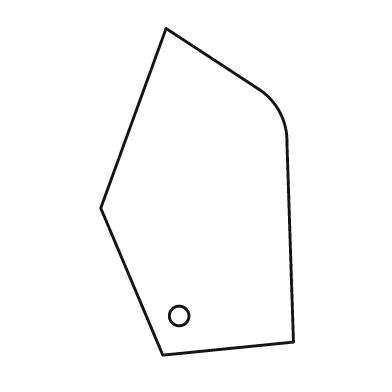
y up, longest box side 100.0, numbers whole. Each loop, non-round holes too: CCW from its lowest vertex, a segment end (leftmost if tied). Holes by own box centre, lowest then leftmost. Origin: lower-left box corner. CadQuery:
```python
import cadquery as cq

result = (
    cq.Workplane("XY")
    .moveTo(19.0, 0.0)
    .lineTo(59.0, 4.0)
    .lineTo(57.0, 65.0)
    .threePointArc((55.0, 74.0), (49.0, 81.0))
    .lineTo(20.0, 100.0)
    .lineTo(0.0, 45.0)
    .close()
    .moveTo(24.0, 12.0)
    .circle(3.0)
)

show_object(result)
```